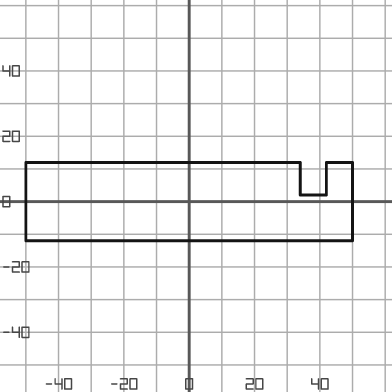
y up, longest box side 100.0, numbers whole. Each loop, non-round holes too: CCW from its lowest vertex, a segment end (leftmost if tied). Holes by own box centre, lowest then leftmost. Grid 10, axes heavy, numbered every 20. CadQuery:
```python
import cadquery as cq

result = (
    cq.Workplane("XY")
    .moveTo(-50.0, -12.0)
    .lineTo(50.0, -12.0)
    .lineTo(50.0, 12.0)
    .lineTo(42.0, 12.0)
    .lineTo(42.0, 2.0)
    .lineTo(34.0, 2.0)
    .lineTo(34.0, 12.0)
    .lineTo(-50.0, 12.0)
    .close()
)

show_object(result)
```